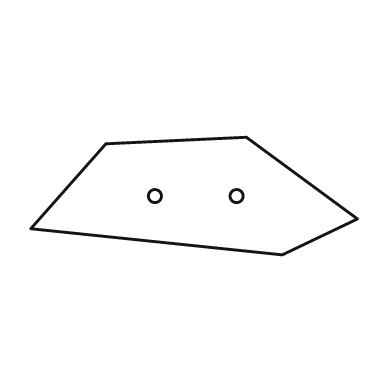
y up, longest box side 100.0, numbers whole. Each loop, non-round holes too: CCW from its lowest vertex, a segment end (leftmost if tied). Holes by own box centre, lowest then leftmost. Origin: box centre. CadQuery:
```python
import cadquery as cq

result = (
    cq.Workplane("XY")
    .moveTo(27.0, -18.0)
    .lineTo(50.0, -7.0)
    .lineTo(16.0, 18.0)
    .lineTo(-27.0, 16.0)
    .lineTo(-50.0, -10.0)
    .close()
    .moveTo(-12.0, 0.0)
    .circle(2.0)
    .moveTo(13.0, 0.0)
    .circle(2.0)
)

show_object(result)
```